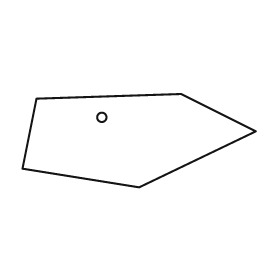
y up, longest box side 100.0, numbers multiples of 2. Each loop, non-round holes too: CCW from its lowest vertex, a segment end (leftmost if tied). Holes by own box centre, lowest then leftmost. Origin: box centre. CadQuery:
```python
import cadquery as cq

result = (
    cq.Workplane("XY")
    .moveTo(0.0, -20.0)
    .lineTo(50.0, 4.0)
    .lineTo(18.0, 20.0)
    .lineTo(-44.0, 18.0)
    .lineTo(-50.0, -12.0)
    .close()
    .moveTo(-16.0, 10.0)
    .circle(2.0)
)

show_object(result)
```